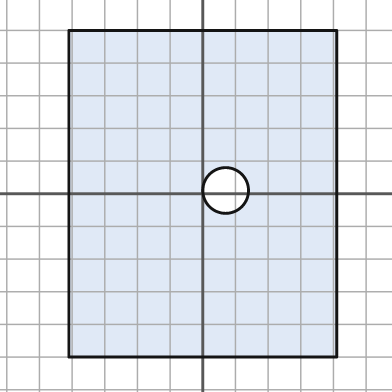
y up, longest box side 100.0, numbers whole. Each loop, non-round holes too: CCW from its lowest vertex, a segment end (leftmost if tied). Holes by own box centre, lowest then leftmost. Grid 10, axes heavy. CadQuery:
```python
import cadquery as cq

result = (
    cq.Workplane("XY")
    .moveTo(-41.0, -50.0)
    .lineTo(41.0, -50.0)
    .lineTo(41.0, 50.0)
    .lineTo(-41.0, 50.0)
    .close()
    .moveTo(7.0, 1.0)
    .circle(7.0)
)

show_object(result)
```